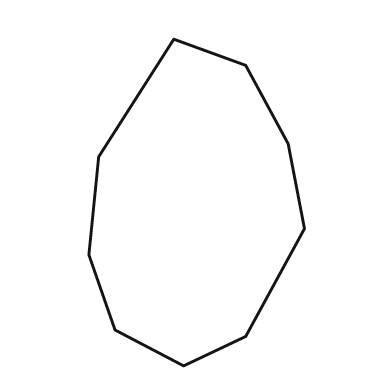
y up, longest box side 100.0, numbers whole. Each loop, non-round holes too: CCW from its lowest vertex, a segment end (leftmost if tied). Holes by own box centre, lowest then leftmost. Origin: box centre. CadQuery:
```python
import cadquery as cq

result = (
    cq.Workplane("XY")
    .moveTo(-4.0, -50.0)
    .lineTo(15.0, -41.0)
    .lineTo(33.0, -8.0)
    .lineTo(28.0, 18.0)
    .lineTo(15.0, 42.0)
    .lineTo(-7.0, 50.0)
    .lineTo(-30.0, 14.0)
    .lineTo(-33.0, -16.0)
    .lineTo(-25.0, -39.0)
    .close()
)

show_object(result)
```